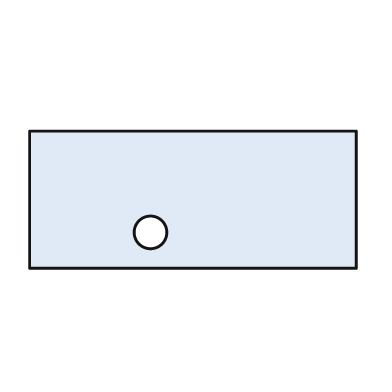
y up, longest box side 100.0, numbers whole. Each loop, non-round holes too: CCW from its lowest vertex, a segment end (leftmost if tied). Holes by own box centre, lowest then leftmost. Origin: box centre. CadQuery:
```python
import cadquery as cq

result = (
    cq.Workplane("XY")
    .moveTo(-50.0, -21.0)
    .lineTo(50.0, -21.0)
    .lineTo(50.0, 21.0)
    .lineTo(-50.0, 21.0)
    .close()
    .moveTo(-13.0, -10.0)
    .circle(5.0)
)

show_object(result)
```